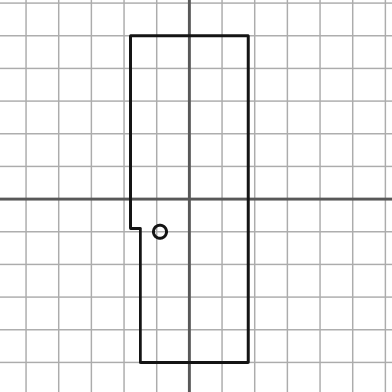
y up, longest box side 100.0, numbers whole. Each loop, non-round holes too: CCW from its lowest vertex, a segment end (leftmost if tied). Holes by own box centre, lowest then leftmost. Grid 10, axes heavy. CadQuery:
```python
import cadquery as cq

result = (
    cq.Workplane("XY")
    .moveTo(-15.0, -50.0)
    .lineTo(18.0, -50.0)
    .lineTo(18.0, 50.0)
    .lineTo(-18.0, 50.0)
    .lineTo(-18.0, -9.0)
    .lineTo(-15.0, -9.0)
    .close()
    .moveTo(-9.0, -10.0)
    .circle(2.0)
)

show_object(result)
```